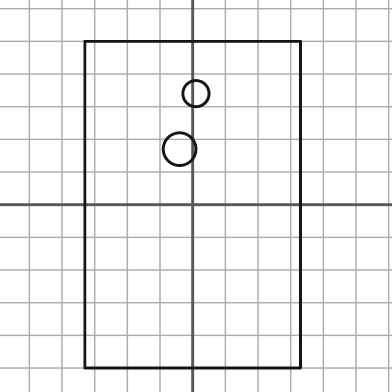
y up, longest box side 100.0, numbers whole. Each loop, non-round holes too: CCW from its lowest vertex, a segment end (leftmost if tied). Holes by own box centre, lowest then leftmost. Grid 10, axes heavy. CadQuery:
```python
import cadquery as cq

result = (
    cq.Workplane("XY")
    .moveTo(-33.0, -50.0)
    .lineTo(33.0, -50.0)
    .lineTo(33.0, 50.0)
    .lineTo(-33.0, 50.0)
    .close()
    .moveTo(-4.0, 17.0)
    .circle(5.0)
    .moveTo(1.0, 34.0)
    .circle(4.0)
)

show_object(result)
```